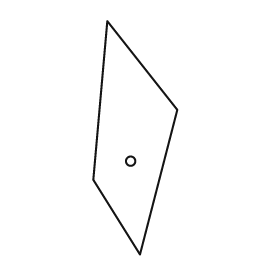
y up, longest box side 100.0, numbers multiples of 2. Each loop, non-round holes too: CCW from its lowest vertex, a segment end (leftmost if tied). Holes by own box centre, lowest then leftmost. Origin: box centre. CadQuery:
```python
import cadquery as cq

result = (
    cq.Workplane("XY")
    .moveTo(2.0, -50.0)
    .lineTo(18.0, 12.0)
    .lineTo(-12.0, 50.0)
    .lineTo(-18.0, -18.0)
    .close()
    .moveTo(-2.0, -10.0)
    .circle(2.0)
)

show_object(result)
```